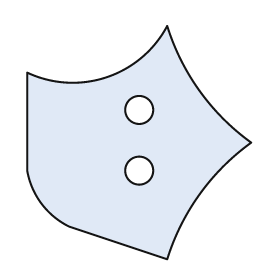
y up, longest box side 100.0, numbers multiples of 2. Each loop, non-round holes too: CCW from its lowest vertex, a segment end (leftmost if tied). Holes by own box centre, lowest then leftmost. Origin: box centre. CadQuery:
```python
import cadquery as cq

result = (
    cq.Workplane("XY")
    .moveTo(12.0, -50.0)
    .threePointArc((26.0, -22.0), (48.0, 0.0))
    .threePointArc((26.0, 22.0), (12.0, 50.0))
    .threePointArc((-14.0, 28.0), (-48.0, 30.0))
    .lineTo(-48.0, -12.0)
    .threePointArc((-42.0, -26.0), (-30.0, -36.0))
    .close()
    .moveTo(0.0, -12.0)
    .circle(6.0)
    .moveTo(0.0, 14.0)
    .circle(6.0)
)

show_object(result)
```